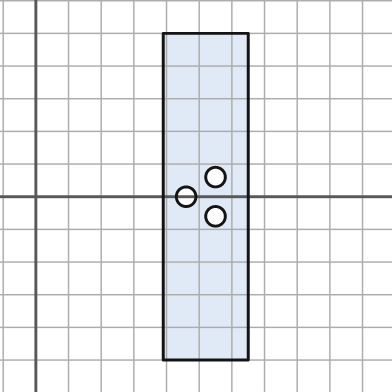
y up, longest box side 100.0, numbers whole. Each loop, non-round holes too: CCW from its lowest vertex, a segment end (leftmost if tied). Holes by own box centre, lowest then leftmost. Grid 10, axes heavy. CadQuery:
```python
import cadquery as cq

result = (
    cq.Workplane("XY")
    .moveTo(39.0, -50.0)
    .lineTo(65.0, -50.0)
    .lineTo(65.0, 50.0)
    .lineTo(39.0, 50.0)
    .close()
    .moveTo(55.0, -6.0)
    .circle(3.0)
    .moveTo(46.0, 0.0)
    .circle(3.0)
    .moveTo(55.0, 6.0)
    .circle(3.0)
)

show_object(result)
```